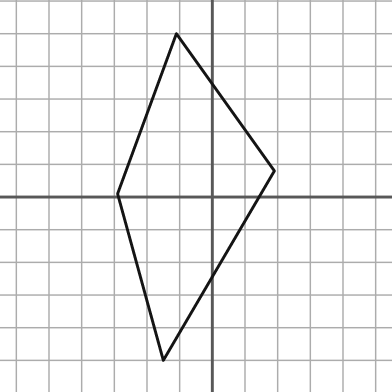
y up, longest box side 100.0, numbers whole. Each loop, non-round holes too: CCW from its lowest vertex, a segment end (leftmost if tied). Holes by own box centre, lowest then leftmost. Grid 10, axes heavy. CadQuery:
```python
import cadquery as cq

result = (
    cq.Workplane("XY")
    .moveTo(-15.0, -50.0)
    .lineTo(19.0, 8.0)
    .lineTo(-11.0, 50.0)
    .lineTo(-29.0, 1.0)
    .close()
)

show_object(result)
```